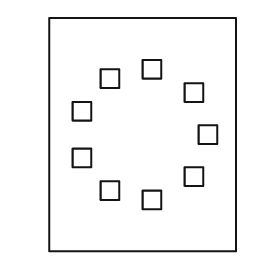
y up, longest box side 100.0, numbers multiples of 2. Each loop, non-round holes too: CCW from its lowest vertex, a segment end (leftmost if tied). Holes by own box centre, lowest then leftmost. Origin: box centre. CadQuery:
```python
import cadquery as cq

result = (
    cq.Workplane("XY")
    .moveTo(-40.0, -50.0)
    .lineTo(40.0, -50.0)
    .lineTo(40.0, 50.0)
    .lineTo(-40.0, 50.0)
    .close()
    .moveTo(0.0, -32.0)
    .lineTo(8.0, -32.0)
    .lineTo(8.0, -24.0)
    .lineTo(0.0, -24.0)
    .close()
    .moveTo(-18.0, -28.0)
    .lineTo(-10.0, -28.0)
    .lineTo(-10.0, -20.0)
    .lineTo(-18.0, -20.0)
    .close()
    .moveTo(18.0, -22.0)
    .lineTo(26.0, -22.0)
    .lineTo(26.0, -14.0)
    .lineTo(18.0, -14.0)
    .close()
    .moveTo(-30.0, -14.0)
    .lineTo(-22.0, -14.0)
    .lineTo(-22.0, -6.0)
    .lineTo(-30.0, -6.0)
    .close()
    .moveTo(24.0, -4.0)
    .lineTo(32.0, -4.0)
    .lineTo(32.0, 4.0)
    .lineTo(24.0, 4.0)
    .close()
    .moveTo(-30.0, 6.0)
    .lineTo(-22.0, 6.0)
    .lineTo(-22.0, 14.0)
    .lineTo(-30.0, 14.0)
    .close()
    .moveTo(18.0, 14.0)
    .lineTo(26.0, 14.0)
    .lineTo(26.0, 22.0)
    .lineTo(18.0, 22.0)
    .close()
    .moveTo(-18.0, 20.0)
    .lineTo(-10.0, 20.0)
    .lineTo(-10.0, 28.0)
    .lineTo(-18.0, 28.0)
    .close()
    .moveTo(0.0, 24.0)
    .lineTo(8.0, 24.0)
    .lineTo(8.0, 32.0)
    .lineTo(0.0, 32.0)
    .close()
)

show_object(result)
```